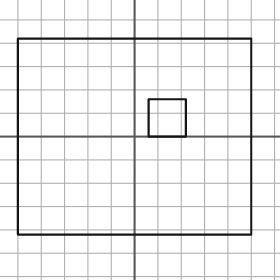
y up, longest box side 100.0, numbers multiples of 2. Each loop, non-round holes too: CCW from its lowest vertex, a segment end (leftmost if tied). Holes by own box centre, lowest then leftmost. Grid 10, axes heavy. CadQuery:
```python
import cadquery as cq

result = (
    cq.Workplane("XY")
    .moveTo(-50.0, -42.0)
    .lineTo(50.0, -42.0)
    .lineTo(50.0, 42.0)
    .lineTo(-50.0, 42.0)
    .close()
    .moveTo(6.0, 0.0)
    .lineTo(22.0, 0.0)
    .lineTo(22.0, 16.0)
    .lineTo(6.0, 16.0)
    .close()
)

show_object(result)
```